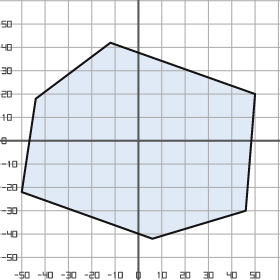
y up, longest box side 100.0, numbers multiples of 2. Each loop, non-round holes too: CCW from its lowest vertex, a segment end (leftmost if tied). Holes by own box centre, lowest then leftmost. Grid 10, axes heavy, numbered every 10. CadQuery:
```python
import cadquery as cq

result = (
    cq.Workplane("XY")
    .moveTo(6.0, -42.0)
    .lineTo(46.0, -30.0)
    .lineTo(50.0, 20.0)
    .lineTo(-12.0, 42.0)
    .lineTo(-44.0, 18.0)
    .lineTo(-50.0, -22.0)
    .close()
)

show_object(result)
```